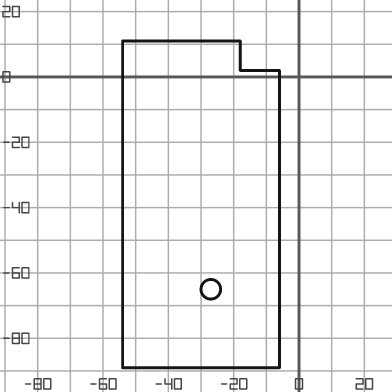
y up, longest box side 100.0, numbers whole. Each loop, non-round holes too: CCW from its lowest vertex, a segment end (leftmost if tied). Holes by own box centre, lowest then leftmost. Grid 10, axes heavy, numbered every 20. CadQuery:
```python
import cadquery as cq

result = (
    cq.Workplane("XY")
    .moveTo(-54.0, -89.0)
    .lineTo(-6.0, -89.0)
    .lineTo(-6.0, 2.0)
    .lineTo(-18.0, 2.0)
    .lineTo(-18.0, 11.0)
    .lineTo(-54.0, 11.0)
    .close()
    .moveTo(-27.0, -65.0)
    .circle(3.0)
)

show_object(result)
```